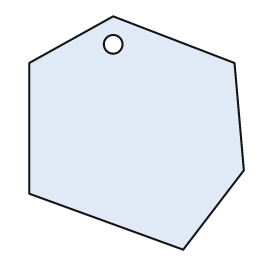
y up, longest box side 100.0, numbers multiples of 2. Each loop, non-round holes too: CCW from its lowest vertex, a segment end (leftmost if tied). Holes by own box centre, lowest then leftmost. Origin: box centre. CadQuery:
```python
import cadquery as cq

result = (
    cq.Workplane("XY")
    .moveTo(20.0, -50.0)
    .lineTo(46.0, -16.0)
    .lineTo(42.0, 30.0)
    .lineTo(-10.0, 50.0)
    .lineTo(-46.0, 30.0)
    .lineTo(-46.0, -26.0)
    .close()
    .moveTo(-10.0, 38.0)
    .circle(4.0)
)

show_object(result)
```